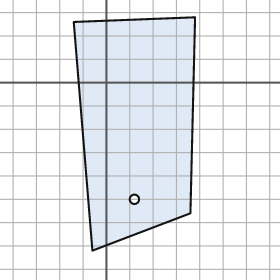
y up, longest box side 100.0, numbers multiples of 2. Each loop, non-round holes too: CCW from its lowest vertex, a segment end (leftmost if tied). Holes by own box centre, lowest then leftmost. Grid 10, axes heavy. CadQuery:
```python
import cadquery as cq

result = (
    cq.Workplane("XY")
    .moveTo(-6.0, -72.0)
    .lineTo(36.0, -56.0)
    .lineTo(38.0, 28.0)
    .lineTo(-14.0, 26.0)
    .close()
    .moveTo(12.0, -50.0)
    .circle(2.0)
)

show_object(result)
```